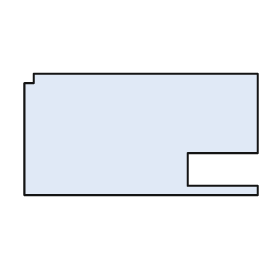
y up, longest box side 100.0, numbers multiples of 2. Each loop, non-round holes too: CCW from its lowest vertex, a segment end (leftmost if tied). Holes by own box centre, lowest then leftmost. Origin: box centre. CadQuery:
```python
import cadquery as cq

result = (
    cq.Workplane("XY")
    .moveTo(-50.0, -26.0)
    .lineTo(50.0, -26.0)
    .lineTo(50.0, -22.0)
    .lineTo(20.0, -22.0)
    .lineTo(20.0, -8.0)
    .lineTo(50.0, -8.0)
    .lineTo(50.0, 26.0)
    .lineTo(-46.0, 26.0)
    .lineTo(-46.0, 22.0)
    .lineTo(-50.0, 22.0)
    .close()
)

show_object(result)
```